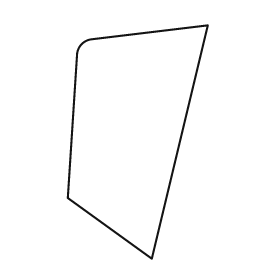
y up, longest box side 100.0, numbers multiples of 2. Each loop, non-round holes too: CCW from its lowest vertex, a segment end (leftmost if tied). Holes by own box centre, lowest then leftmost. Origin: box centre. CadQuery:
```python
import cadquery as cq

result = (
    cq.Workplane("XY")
    .moveTo(6.0, -50.0)
    .lineTo(30.0, 50.0)
    .lineTo(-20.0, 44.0)
    .threePointArc((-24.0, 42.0), (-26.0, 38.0))
    .lineTo(-30.0, -24.0)
    .close()
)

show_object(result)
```